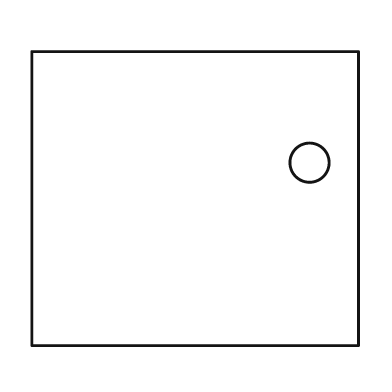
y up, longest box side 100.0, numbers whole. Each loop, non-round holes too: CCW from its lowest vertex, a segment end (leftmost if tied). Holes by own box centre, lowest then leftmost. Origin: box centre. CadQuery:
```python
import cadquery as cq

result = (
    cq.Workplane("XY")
    .moveTo(-50.0, -45.0)
    .lineTo(50.0, -45.0)
    .lineTo(50.0, 45.0)
    .lineTo(-50.0, 45.0)
    .close()
    .moveTo(35.0, 11.0)
    .circle(6.0)
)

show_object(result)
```